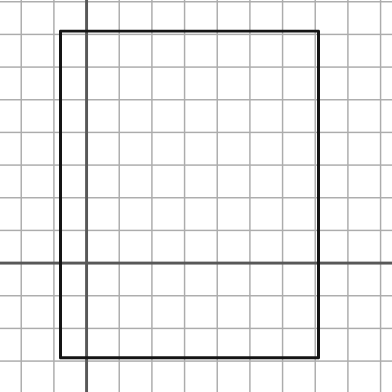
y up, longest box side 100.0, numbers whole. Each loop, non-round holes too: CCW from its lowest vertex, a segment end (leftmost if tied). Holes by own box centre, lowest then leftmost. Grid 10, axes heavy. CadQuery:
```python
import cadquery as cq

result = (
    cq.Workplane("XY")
    .moveTo(-8.0, -29.0)
    .lineTo(71.0, -29.0)
    .lineTo(71.0, 71.0)
    .lineTo(-8.0, 71.0)
    .close()
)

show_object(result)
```